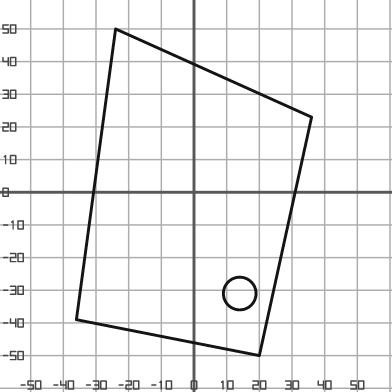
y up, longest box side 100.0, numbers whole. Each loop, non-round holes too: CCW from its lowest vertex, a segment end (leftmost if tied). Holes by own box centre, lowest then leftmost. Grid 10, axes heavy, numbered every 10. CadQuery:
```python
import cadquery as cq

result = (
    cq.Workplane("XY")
    .moveTo(20.0, -50.0)
    .lineTo(36.0, 23.0)
    .lineTo(-24.0, 50.0)
    .lineTo(-36.0, -39.0)
    .close()
    .moveTo(14.0, -31.0)
    .circle(5.0)
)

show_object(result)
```